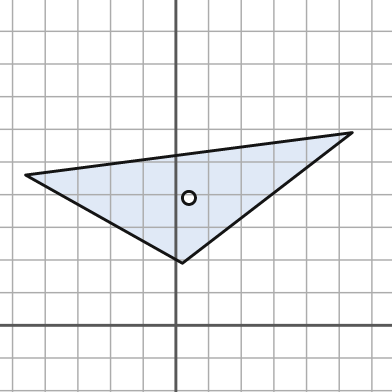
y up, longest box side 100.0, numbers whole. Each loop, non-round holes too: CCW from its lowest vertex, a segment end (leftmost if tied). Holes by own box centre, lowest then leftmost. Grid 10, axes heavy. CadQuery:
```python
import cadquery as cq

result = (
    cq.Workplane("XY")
    .moveTo(2.0, 19.0)
    .lineTo(54.0, 59.0)
    .lineTo(-46.0, 46.0)
    .close()
    .moveTo(4.0, 39.0)
    .circle(2.0)
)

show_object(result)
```